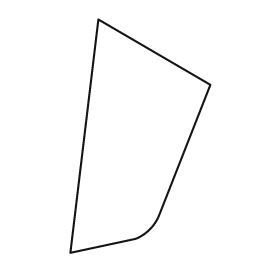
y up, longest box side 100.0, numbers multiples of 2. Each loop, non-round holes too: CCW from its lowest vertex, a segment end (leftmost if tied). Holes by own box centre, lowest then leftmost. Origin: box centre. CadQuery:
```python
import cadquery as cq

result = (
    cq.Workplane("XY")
    .moveTo(-30.0, -50.0)
    .lineTo(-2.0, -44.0)
    .threePointArc((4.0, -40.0), (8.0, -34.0))
    .lineTo(30.0, 22.0)
    .lineTo(-18.0, 50.0)
    .close()
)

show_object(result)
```